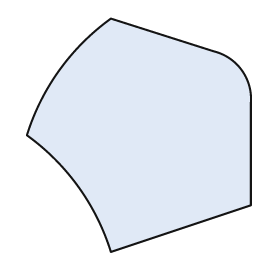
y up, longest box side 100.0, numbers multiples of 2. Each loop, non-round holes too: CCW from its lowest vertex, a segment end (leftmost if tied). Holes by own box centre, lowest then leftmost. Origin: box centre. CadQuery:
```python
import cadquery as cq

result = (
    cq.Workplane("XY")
    .moveTo(-12.0, -50.0)
    .lineTo(48.0, -30.0)
    .lineTo(48.0, 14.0)
    .threePointArc((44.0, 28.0), (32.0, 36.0))
    .lineTo(-12.0, 50.0)
    .threePointArc((-34.0, 28.0), (-48.0, 0.0))
    .threePointArc((-26.0, -22.0), (-12.0, -50.0))
    .close()
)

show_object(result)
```